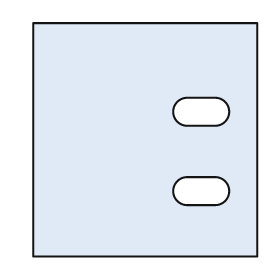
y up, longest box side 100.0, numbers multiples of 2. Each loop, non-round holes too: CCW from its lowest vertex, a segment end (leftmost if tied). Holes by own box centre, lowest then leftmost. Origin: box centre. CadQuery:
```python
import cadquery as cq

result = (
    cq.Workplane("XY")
    .moveTo(-48.0, -50.0)
    .lineTo(48.0, -50.0)
    .lineTo(48.0, 50.0)
    .lineTo(-48.0, 50.0)
    .close()
    .moveTo(18.0, -28.0)
    .lineTo(30.0, -28.0)
    .threePointArc((36.0, -22.0), (30.0, -16.0))
    .lineTo(18.0, -16.0)
    .threePointArc((12.0, -22.0), (18.0, -28.0))
    .close()
    .moveTo(18.0, 6.0)
    .lineTo(30.0, 6.0)
    .threePointArc((36.0, 12.0), (30.0, 18.0))
    .lineTo(18.0, 18.0)
    .threePointArc((12.0, 12.0), (18.0, 6.0))
    .close()
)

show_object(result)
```